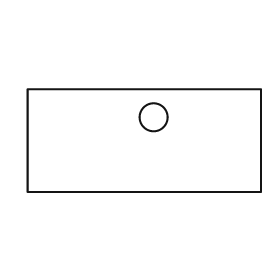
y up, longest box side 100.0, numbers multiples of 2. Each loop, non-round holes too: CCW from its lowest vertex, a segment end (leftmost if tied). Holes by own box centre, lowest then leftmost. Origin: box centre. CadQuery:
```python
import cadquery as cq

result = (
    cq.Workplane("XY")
    .moveTo(-50.0, -22.0)
    .lineTo(50.0, -22.0)
    .lineTo(50.0, 22.0)
    .lineTo(-50.0, 22.0)
    .close()
    .moveTo(4.0, 10.0)
    .circle(6.0)
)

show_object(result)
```